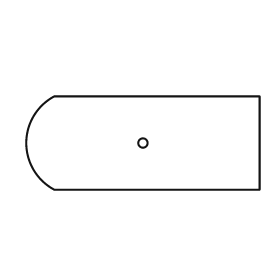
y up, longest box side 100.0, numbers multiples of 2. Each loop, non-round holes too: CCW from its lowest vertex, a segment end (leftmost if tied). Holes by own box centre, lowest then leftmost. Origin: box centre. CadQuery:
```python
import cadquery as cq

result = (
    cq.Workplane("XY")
    .moveTo(-38.0, -20.0)
    .lineTo(50.0, -20.0)
    .lineTo(50.0, 20.0)
    .lineTo(-38.0, 20.0)
    .threePointArc((-50.0, 0.0), (-38.0, -20.0))
    .close()
    .moveTo(0.0, 0.0)
    .circle(2.0)
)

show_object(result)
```